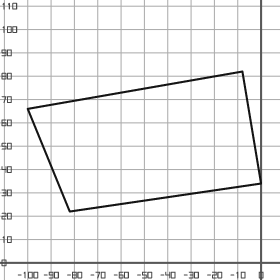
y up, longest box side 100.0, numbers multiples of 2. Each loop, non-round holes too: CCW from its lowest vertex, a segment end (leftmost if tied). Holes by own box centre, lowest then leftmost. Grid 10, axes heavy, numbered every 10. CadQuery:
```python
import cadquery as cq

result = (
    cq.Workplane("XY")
    .moveTo(-82.0, 22.0)
    .lineTo(0.0, 34.0)
    .lineTo(-8.0, 82.0)
    .lineTo(-100.0, 66.0)
    .close()
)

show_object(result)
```